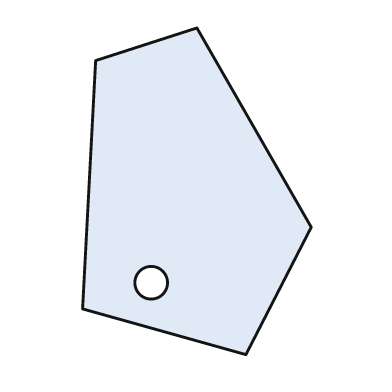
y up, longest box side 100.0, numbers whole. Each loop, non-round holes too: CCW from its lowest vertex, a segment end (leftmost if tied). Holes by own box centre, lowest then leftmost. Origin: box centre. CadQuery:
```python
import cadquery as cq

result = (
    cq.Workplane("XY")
    .moveTo(15.0, -50.0)
    .lineTo(35.0, -11.0)
    .lineTo(0.0, 50.0)
    .lineTo(-31.0, 40.0)
    .lineTo(-35.0, -36.0)
    .close()
    .moveTo(-14.0, -28.0)
    .circle(5.0)
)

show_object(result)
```